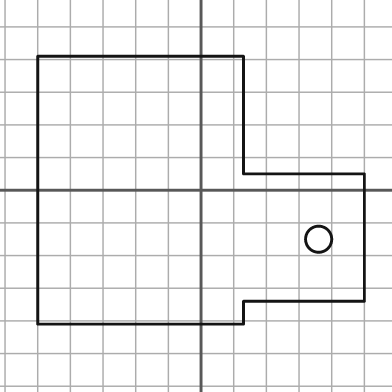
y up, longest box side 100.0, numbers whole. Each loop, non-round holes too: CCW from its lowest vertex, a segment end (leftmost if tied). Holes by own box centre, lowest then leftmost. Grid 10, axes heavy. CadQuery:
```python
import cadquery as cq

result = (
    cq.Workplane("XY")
    .moveTo(-50.0, -41.0)
    .lineTo(13.0, -41.0)
    .lineTo(13.0, -34.0)
    .lineTo(50.0, -34.0)
    .lineTo(50.0, 5.0)
    .lineTo(13.0, 5.0)
    .lineTo(13.0, 41.0)
    .lineTo(-50.0, 41.0)
    .close()
    .moveTo(36.0, -15.0)
    .circle(4.0)
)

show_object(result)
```